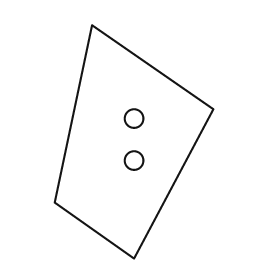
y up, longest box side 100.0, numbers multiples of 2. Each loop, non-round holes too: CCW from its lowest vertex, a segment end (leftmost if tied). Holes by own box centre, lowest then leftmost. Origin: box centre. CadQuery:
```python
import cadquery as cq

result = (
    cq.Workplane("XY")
    .moveTo(0.0, -50.0)
    .lineTo(34.0, 14.0)
    .lineTo(-18.0, 50.0)
    .lineTo(-34.0, -26.0)
    .close()
    .moveTo(0.0, -8.0)
    .circle(4.0)
    .moveTo(0.0, 10.0)
    .circle(4.0)
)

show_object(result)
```